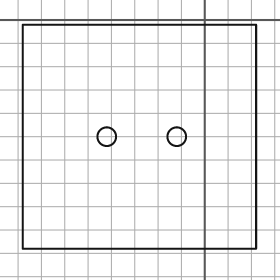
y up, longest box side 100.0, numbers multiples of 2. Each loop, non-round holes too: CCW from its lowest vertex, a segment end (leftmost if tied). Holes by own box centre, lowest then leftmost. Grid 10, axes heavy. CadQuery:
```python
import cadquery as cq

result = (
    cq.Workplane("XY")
    .moveTo(-78.0, -98.0)
    .lineTo(22.0, -98.0)
    .lineTo(22.0, -2.0)
    .lineTo(-78.0, -2.0)
    .close()
    .moveTo(-42.0, -50.0)
    .circle(4.0)
    .moveTo(-12.0, -50.0)
    .circle(4.0)
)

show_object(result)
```